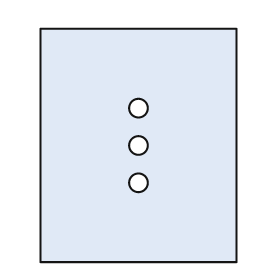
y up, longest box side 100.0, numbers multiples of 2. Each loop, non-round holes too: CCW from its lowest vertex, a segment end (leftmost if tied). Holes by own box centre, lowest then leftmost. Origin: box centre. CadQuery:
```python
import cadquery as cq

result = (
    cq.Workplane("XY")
    .moveTo(-42.0, -50.0)
    .lineTo(42.0, -50.0)
    .lineTo(42.0, 50.0)
    .lineTo(-42.0, 50.0)
    .close()
    .moveTo(0.0, -16.0)
    .circle(4.0)
    .moveTo(0.0, 0.0)
    .circle(4.0)
    .moveTo(0.0, 16.0)
    .circle(4.0)
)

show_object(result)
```